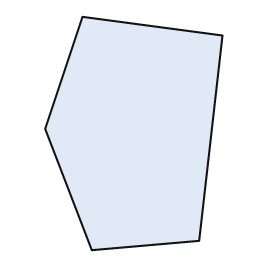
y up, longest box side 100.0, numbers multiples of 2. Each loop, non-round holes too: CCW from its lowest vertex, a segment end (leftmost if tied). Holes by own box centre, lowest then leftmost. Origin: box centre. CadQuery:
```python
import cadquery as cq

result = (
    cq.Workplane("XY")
    .moveTo(-18.0, -50.0)
    .lineTo(28.0, -46.0)
    .lineTo(38.0, 42.0)
    .lineTo(-22.0, 50.0)
    .lineTo(-38.0, 2.0)
    .close()
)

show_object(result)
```